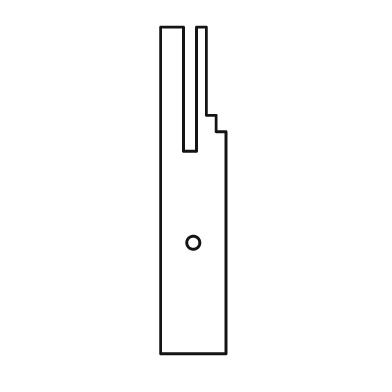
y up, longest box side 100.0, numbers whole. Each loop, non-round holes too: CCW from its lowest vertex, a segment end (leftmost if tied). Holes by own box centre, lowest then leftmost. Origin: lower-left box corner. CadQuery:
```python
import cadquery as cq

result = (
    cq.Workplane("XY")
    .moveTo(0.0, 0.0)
    .lineTo(20.0, 0.0)
    .lineTo(20.0, 68.0)
    .lineTo(17.0, 68.0)
    .lineTo(17.0, 73.0)
    .lineTo(14.0, 73.0)
    .lineTo(14.0, 100.0)
    .lineTo(11.0, 100.0)
    .lineTo(11.0, 62.0)
    .lineTo(7.0, 62.0)
    .lineTo(7.0, 100.0)
    .lineTo(0.0, 100.0)
    .close()
    .moveTo(10.0, 34.0)
    .circle(2.0)
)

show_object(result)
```